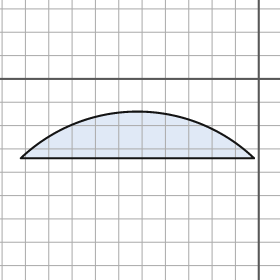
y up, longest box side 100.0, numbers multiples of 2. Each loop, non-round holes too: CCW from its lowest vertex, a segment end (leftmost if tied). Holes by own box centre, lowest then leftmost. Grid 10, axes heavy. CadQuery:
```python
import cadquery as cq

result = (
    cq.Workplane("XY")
    .moveTo(-102.0, -34.0)
    .lineTo(-2.0, -34.0)
    .threePointArc((-52.0, -14.0), (-102.0, -34.0))
    .close()
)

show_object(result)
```